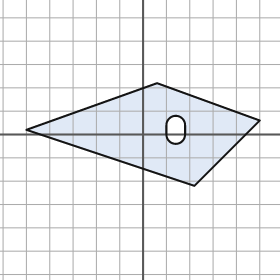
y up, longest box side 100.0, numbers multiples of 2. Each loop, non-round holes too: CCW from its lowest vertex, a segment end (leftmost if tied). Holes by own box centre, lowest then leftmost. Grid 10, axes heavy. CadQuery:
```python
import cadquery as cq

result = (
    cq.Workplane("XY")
    .moveTo(22.0, -22.0)
    .lineTo(50.0, 6.0)
    .lineTo(6.0, 22.0)
    .lineTo(-50.0, 2.0)
    .close()
    .moveTo(10.0, 0.0)
    .threePointArc((14.0, -4.0), (18.0, 0.0))
    .lineTo(18.0, 4.0)
    .threePointArc((14.0, 8.0), (10.0, 4.0))
    .close()
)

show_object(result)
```